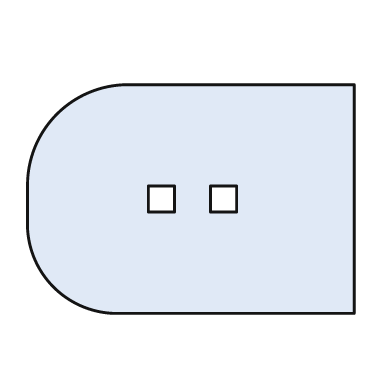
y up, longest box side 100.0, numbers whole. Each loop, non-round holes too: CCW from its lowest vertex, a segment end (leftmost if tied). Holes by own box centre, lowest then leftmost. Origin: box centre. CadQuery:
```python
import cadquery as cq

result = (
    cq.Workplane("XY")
    .moveTo(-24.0, -35.0)
    .lineTo(50.0, -35.0)
    .lineTo(50.0, 35.0)
    .lineTo(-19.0, 35.0)
    .threePointArc((-41.0, 26.0), (-50.0, 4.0))
    .lineTo(-50.0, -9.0)
    .threePointArc((-42.0, -27.0), (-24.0, -35.0))
    .close()
    .moveTo(-13.0, -4.0)
    .lineTo(-5.0, -4.0)
    .lineTo(-5.0, 4.0)
    .lineTo(-13.0, 4.0)
    .close()
    .moveTo(6.0, -4.0)
    .lineTo(14.0, -4.0)
    .lineTo(14.0, 4.0)
    .lineTo(6.0, 4.0)
    .close()
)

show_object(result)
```